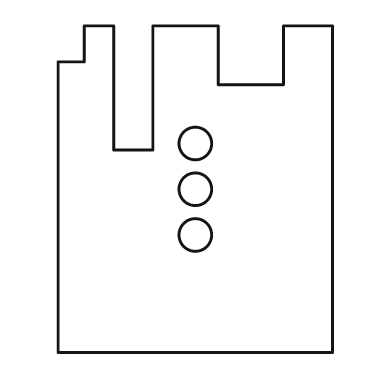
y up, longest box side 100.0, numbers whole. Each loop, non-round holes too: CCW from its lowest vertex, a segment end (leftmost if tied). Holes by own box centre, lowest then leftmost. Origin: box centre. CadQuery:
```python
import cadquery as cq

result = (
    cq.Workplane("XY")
    .moveTo(-42.0, -50.0)
    .lineTo(42.0, -50.0)
    .lineTo(42.0, 50.0)
    .lineTo(27.0, 50.0)
    .lineTo(27.0, 32.0)
    .lineTo(7.0, 32.0)
    .lineTo(7.0, 50.0)
    .lineTo(-13.0, 50.0)
    .lineTo(-13.0, 12.0)
    .lineTo(-25.0, 12.0)
    .lineTo(-25.0, 50.0)
    .lineTo(-34.0, 50.0)
    .lineTo(-34.0, 39.0)
    .lineTo(-42.0, 39.0)
    .close()
    .moveTo(0.0, -14.0)
    .circle(5.0)
    .moveTo(0.0, 0.0)
    .circle(5.0)
    .moveTo(0.0, 14.0)
    .circle(5.0)
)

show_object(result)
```